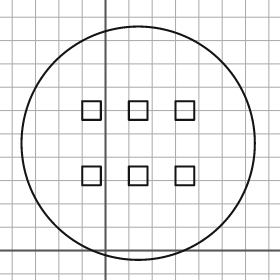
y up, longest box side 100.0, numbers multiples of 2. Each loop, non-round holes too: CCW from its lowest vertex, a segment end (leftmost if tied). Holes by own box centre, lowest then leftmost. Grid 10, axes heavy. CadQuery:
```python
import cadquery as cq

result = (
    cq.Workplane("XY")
    .moveTo(14.0, 46.0)
    .circle(50.0)
    .moveTo(-10.0, 28.0)
    .lineTo(-2.0, 28.0)
    .lineTo(-2.0, 36.0)
    .lineTo(-10.0, 36.0)
    .close()
    .moveTo(10.0, 28.0)
    .lineTo(18.0, 28.0)
    .lineTo(18.0, 36.0)
    .lineTo(10.0, 36.0)
    .close()
    .moveTo(30.0, 28.0)
    .lineTo(38.0, 28.0)
    .lineTo(38.0, 36.0)
    .lineTo(30.0, 36.0)
    .close()
    .moveTo(-10.0, 56.0)
    .lineTo(-2.0, 56.0)
    .lineTo(-2.0, 64.0)
    .lineTo(-10.0, 64.0)
    .close()
    .moveTo(10.0, 56.0)
    .lineTo(18.0, 56.0)
    .lineTo(18.0, 64.0)
    .lineTo(10.0, 64.0)
    .close()
    .moveTo(30.0, 56.0)
    .lineTo(38.0, 56.0)
    .lineTo(38.0, 64.0)
    .lineTo(30.0, 64.0)
    .close()
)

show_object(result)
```